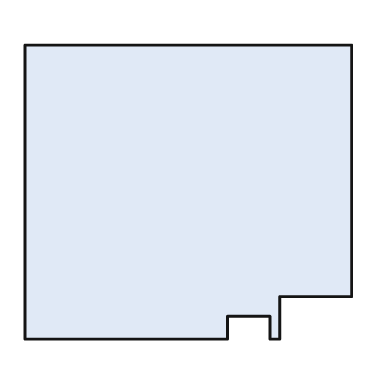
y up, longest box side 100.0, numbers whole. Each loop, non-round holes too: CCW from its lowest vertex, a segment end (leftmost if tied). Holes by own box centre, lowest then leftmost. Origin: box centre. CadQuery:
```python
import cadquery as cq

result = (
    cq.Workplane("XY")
    .moveTo(-50.0, -45.0)
    .lineTo(12.0, -45.0)
    .lineTo(12.0, -38.0)
    .lineTo(25.0, -38.0)
    .lineTo(25.0, -45.0)
    .lineTo(28.0, -45.0)
    .lineTo(28.0, -32.0)
    .lineTo(50.0, -32.0)
    .lineTo(50.0, 45.0)
    .lineTo(-50.0, 45.0)
    .close()
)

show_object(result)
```